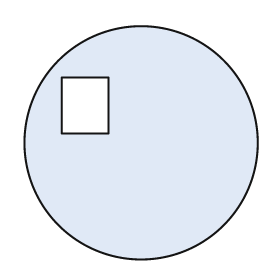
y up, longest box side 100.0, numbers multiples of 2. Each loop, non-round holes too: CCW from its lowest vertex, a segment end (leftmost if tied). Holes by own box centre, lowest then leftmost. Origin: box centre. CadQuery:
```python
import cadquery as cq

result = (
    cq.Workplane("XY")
    .moveTo(0.0, 0.0)
    .circle(50.0)
    .moveTo(-34.0, 4.0)
    .lineTo(-14.0, 4.0)
    .lineTo(-14.0, 28.0)
    .lineTo(-34.0, 28.0)
    .close()
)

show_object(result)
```